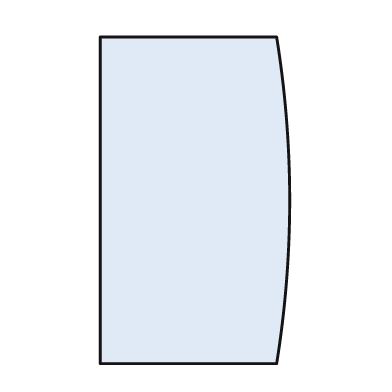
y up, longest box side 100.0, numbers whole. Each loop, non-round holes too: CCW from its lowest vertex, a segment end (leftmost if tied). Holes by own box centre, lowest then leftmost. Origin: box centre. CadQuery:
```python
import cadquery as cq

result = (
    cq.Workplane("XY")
    .moveTo(-29.0, -50.0)
    .lineTo(25.0, -50.0)
    .threePointArc((29.0, 0.0), (25.0, 50.0))
    .lineTo(-29.0, 50.0)
    .close()
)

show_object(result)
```